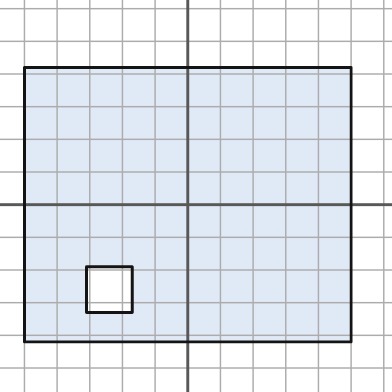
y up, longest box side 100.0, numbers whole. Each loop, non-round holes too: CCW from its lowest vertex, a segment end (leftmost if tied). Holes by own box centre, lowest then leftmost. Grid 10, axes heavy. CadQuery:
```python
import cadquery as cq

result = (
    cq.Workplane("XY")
    .moveTo(-50.0, -42.0)
    .lineTo(50.0, -42.0)
    .lineTo(50.0, 42.0)
    .lineTo(-50.0, 42.0)
    .close()
    .moveTo(-31.0, -33.0)
    .lineTo(-17.0, -33.0)
    .lineTo(-17.0, -19.0)
    .lineTo(-31.0, -19.0)
    .close()
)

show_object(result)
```